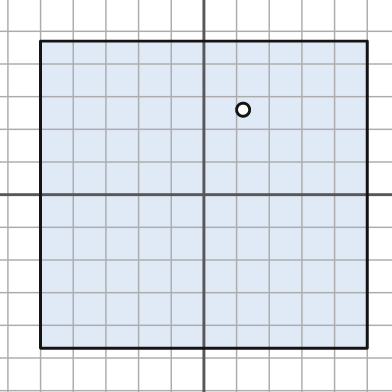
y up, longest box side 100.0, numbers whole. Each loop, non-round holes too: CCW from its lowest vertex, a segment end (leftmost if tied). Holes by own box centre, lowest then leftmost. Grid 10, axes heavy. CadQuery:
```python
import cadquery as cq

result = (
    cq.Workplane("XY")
    .moveTo(-50.0, -47.0)
    .lineTo(50.0, -47.0)
    .lineTo(50.0, 47.0)
    .lineTo(-50.0, 47.0)
    .close()
    .moveTo(12.0, 26.0)
    .circle(2.0)
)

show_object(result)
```